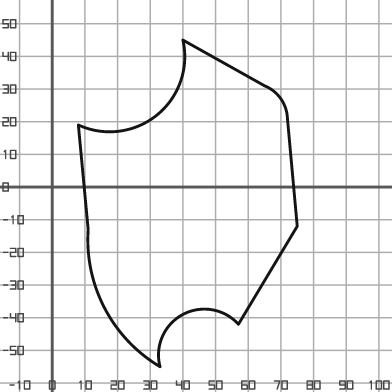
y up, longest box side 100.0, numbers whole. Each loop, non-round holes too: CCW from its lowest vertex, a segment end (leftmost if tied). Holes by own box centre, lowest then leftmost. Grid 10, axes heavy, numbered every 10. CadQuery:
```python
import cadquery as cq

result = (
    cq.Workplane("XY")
    .moveTo(33.0, -55.0)
    .threePointArc((40.0, -39.0), (57.0, -42.0))
    .lineTo(75.0, -12.0)
    .lineTo(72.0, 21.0)
    .threePointArc((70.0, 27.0), (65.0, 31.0))
    .lineTo(40.0, 45.0)
    .threePointArc((32.0, 22.0), (8.0, 19.0))
    .lineTo(11.0, -13.0)
    .threePointArc((16.0, -37.0), (33.0, -55.0))
    .close()
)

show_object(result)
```